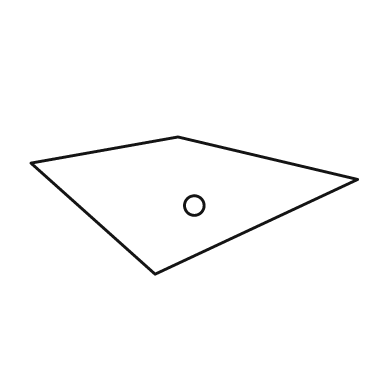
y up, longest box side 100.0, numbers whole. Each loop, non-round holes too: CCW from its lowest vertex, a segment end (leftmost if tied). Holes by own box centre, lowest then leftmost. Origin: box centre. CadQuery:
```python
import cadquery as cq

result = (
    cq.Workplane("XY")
    .moveTo(-12.0, -21.0)
    .lineTo(50.0, 8.0)
    .lineTo(-5.0, 21.0)
    .lineTo(-50.0, 13.0)
    .close()
    .moveTo(0.0, 0.0)
    .circle(3.0)
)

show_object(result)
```